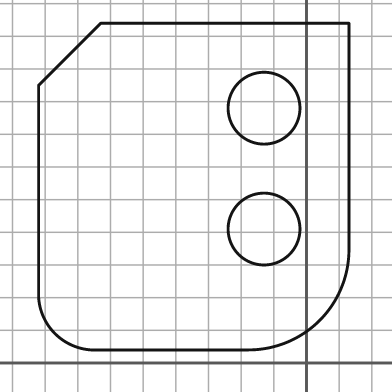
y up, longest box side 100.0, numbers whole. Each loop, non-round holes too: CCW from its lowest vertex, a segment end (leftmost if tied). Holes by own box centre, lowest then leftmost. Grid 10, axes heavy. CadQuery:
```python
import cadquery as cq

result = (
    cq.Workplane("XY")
    .moveTo(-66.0, 4.0)
    .lineTo(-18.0, 4.0)
    .threePointArc((4.0, 13.0), (13.0, 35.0))
    .lineTo(13.0, 104.0)
    .lineTo(-63.0, 104.0)
    .lineTo(-82.0, 85.0)
    .lineTo(-82.0, 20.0)
    .threePointArc((-77.0, 9.0), (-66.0, 4.0))
    .close()
    .moveTo(-13.0, 41.0)
    .circle(11.0)
    .moveTo(-13.0, 78.0)
    .circle(11.0)
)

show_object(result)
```